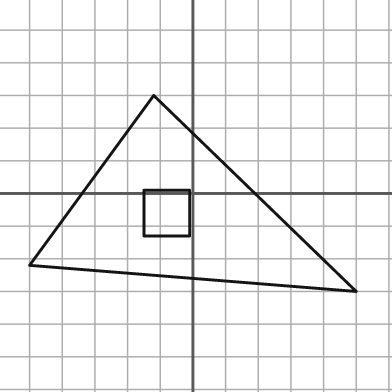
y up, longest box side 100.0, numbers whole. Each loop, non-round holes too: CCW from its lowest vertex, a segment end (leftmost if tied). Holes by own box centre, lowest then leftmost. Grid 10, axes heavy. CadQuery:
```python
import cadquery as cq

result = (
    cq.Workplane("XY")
    .moveTo(50.0, -30.0)
    .lineTo(-12.0, 30.0)
    .lineTo(-50.0, -22.0)
    .close()
    .moveTo(-15.0, -13.0)
    .lineTo(-1.0, -13.0)
    .lineTo(-1.0, 1.0)
    .lineTo(-15.0, 1.0)
    .close()
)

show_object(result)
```